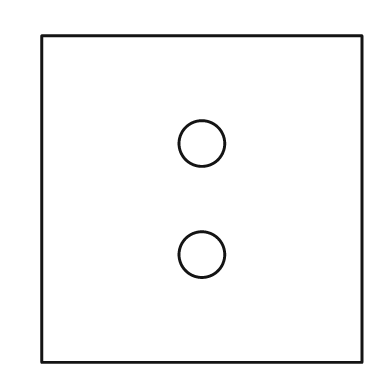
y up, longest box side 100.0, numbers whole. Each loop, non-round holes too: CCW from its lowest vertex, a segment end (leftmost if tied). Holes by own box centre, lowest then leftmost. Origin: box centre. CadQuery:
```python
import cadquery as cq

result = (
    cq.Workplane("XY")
    .moveTo(-49.0, -50.0)
    .lineTo(49.0, -50.0)
    .lineTo(49.0, 50.0)
    .lineTo(-49.0, 50.0)
    .close()
    .moveTo(0.0, -17.0)
    .circle(7.0)
    .moveTo(0.0, 17.0)
    .circle(7.0)
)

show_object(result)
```